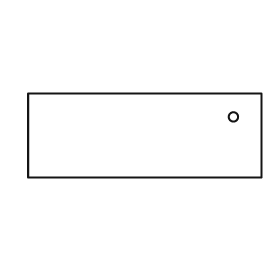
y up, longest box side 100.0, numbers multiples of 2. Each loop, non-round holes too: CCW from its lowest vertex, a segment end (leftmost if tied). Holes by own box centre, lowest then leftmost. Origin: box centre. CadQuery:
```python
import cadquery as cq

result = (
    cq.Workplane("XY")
    .moveTo(-50.0, -18.0)
    .lineTo(50.0, -18.0)
    .lineTo(50.0, 18.0)
    .lineTo(-50.0, 18.0)
    .close()
    .moveTo(38.0, 8.0)
    .circle(2.0)
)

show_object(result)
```